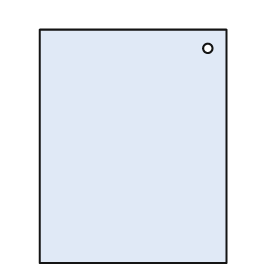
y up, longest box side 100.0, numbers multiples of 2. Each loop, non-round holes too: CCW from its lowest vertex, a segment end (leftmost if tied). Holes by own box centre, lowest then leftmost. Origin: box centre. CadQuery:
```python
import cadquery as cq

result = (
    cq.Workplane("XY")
    .moveTo(-40.0, -50.0)
    .lineTo(40.0, -50.0)
    .lineTo(40.0, 50.0)
    .lineTo(-40.0, 50.0)
    .close()
    .moveTo(32.0, 42.0)
    .circle(2.0)
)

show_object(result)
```